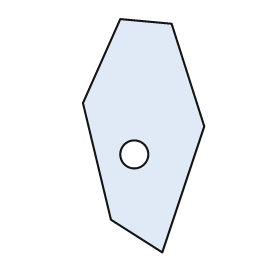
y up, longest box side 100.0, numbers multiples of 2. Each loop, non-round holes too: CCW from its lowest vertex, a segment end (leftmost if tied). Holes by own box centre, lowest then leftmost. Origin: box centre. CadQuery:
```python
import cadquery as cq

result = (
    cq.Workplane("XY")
    .moveTo(8.0, -50.0)
    .lineTo(26.0, 4.0)
    .lineTo(12.0, 48.0)
    .lineTo(-10.0, 50.0)
    .lineTo(-26.0, 14.0)
    .lineTo(-14.0, -36.0)
    .close()
    .moveTo(-4.0, -8.0)
    .circle(6.0)
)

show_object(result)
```